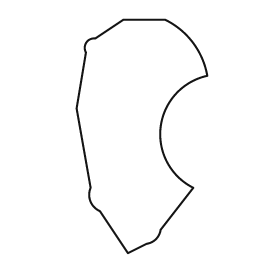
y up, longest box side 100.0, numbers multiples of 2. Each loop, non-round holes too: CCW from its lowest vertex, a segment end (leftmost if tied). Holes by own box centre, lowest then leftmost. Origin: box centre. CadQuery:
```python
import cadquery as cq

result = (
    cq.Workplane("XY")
    .moveTo(-6.0, -50.0)
    .lineTo(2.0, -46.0)
    .threePointArc((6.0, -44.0), (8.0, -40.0))
    .lineTo(22.0, -22.0)
    .threePointArc((8.0, 4.0), (28.0, 26.0))
    .threePointArc((22.0, 40.0), (10.0, 50.0))
    .lineTo(-8.0, 50.0)
    .lineTo(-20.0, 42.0)
    .threePointArc((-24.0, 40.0), (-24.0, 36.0))
    .lineTo(-28.0, 12.0)
    .lineTo(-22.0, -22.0)
    .threePointArc((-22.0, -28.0), (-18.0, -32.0))
    .close()
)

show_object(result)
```